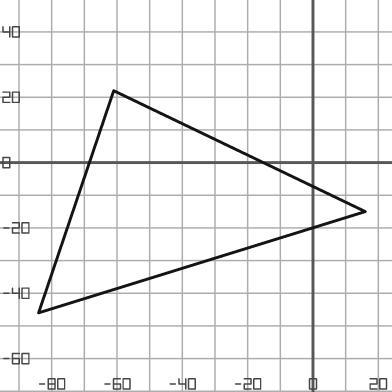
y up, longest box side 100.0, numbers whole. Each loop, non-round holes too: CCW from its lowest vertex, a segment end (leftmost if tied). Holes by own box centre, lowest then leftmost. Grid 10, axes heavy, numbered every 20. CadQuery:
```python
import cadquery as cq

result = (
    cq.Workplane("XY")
    .moveTo(-84.0, -46.0)
    .lineTo(16.0, -15.0)
    .lineTo(-61.0, 22.0)
    .close()
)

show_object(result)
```